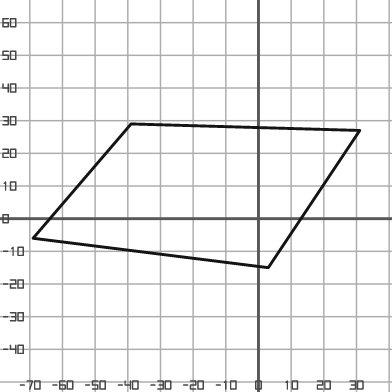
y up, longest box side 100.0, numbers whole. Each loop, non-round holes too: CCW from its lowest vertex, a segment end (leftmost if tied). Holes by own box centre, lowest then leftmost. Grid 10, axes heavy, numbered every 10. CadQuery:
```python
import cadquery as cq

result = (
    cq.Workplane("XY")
    .moveTo(3.0, -15.0)
    .lineTo(31.0, 27.0)
    .lineTo(-39.0, 29.0)
    .lineTo(-69.0, -6.0)
    .close()
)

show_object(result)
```